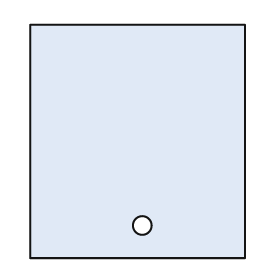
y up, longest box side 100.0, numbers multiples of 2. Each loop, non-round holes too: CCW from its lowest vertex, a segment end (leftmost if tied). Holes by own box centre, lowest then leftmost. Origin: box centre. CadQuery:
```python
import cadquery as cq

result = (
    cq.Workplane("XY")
    .moveTo(-46.0, -50.0)
    .lineTo(46.0, -50.0)
    .lineTo(46.0, 50.0)
    .lineTo(-46.0, 50.0)
    .close()
    .moveTo(2.0, -36.0)
    .circle(4.0)
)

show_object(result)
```